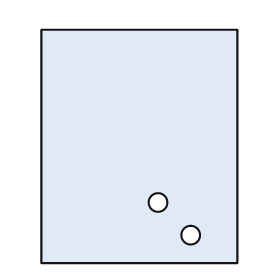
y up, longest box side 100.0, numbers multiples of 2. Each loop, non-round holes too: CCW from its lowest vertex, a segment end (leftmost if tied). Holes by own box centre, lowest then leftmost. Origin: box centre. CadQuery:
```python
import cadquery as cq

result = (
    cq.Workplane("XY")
    .moveTo(-42.0, -50.0)
    .lineTo(42.0, -50.0)
    .lineTo(42.0, 50.0)
    .lineTo(-42.0, 50.0)
    .close()
    .moveTo(22.0, -38.0)
    .circle(4.0)
    .moveTo(8.0, -24.0)
    .circle(4.0)
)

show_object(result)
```